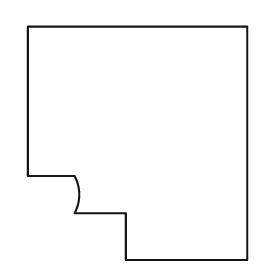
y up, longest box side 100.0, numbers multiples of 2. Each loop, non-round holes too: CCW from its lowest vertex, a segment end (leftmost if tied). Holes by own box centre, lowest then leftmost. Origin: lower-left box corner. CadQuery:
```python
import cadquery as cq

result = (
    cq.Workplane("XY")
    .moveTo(42.0, 0.0)
    .lineTo(94.0, 0.0)
    .lineTo(94.0, 100.0)
    .lineTo(0.0, 100.0)
    .lineTo(0.0, 36.0)
    .lineTo(20.0, 36.0)
    .threePointArc((22.0, 28.0), (20.0, 20.0))
    .lineTo(42.0, 20.0)
    .close()
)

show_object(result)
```